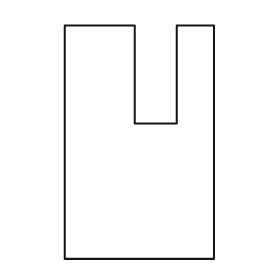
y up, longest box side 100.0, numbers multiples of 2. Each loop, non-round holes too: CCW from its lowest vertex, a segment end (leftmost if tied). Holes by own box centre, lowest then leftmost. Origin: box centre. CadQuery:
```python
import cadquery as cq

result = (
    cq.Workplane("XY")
    .moveTo(-32.0, -50.0)
    .lineTo(32.0, -50.0)
    .lineTo(32.0, 50.0)
    .lineTo(16.0, 50.0)
    .lineTo(16.0, 8.0)
    .lineTo(-2.0, 8.0)
    .lineTo(-2.0, 50.0)
    .lineTo(-32.0, 50.0)
    .close()
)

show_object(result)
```